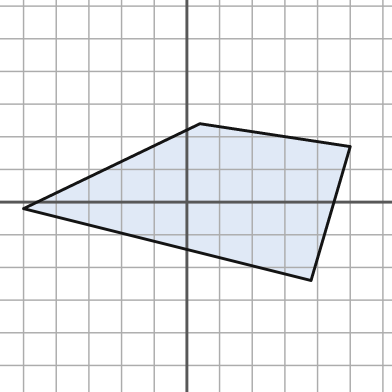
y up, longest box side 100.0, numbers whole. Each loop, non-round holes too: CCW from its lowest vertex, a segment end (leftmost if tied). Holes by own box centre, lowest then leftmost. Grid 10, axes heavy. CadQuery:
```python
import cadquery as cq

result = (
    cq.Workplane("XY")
    .moveTo(38.0, -24.0)
    .lineTo(50.0, 17.0)
    .lineTo(4.0, 24.0)
    .lineTo(-50.0, -2.0)
    .close()
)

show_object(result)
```